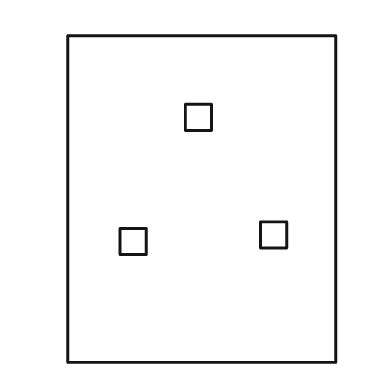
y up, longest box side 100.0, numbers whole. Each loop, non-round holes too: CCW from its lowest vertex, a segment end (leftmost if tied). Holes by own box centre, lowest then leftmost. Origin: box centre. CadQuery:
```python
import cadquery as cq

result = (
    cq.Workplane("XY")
    .moveTo(-41.0, -50.0)
    .lineTo(41.0, -50.0)
    .lineTo(41.0, 50.0)
    .lineTo(-41.0, 50.0)
    .close()
    .moveTo(-25.0, -17.0)
    .lineTo(-17.0, -17.0)
    .lineTo(-17.0, -9.0)
    .lineTo(-25.0, -9.0)
    .close()
    .moveTo(18.0, -15.0)
    .lineTo(26.0, -15.0)
    .lineTo(26.0, -7.0)
    .lineTo(18.0, -7.0)
    .close()
    .moveTo(-5.0, 21.0)
    .lineTo(3.0, 21.0)
    .lineTo(3.0, 29.0)
    .lineTo(-5.0, 29.0)
    .close()
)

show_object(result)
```